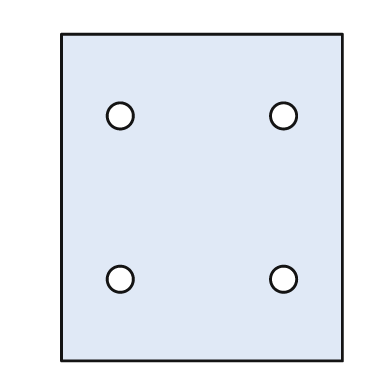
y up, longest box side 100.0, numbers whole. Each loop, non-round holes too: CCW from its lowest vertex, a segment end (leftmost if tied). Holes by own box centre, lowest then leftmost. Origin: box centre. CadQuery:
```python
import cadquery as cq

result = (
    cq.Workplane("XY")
    .moveTo(-43.0, -50.0)
    .lineTo(43.0, -50.0)
    .lineTo(43.0, 50.0)
    .lineTo(-43.0, 50.0)
    .close()
    .moveTo(-25.0, -25.0)
    .circle(4.0)
    .moveTo(25.0, -25.0)
    .circle(4.0)
    .moveTo(-25.0, 25.0)
    .circle(4.0)
    .moveTo(25.0, 25.0)
    .circle(4.0)
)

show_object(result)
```